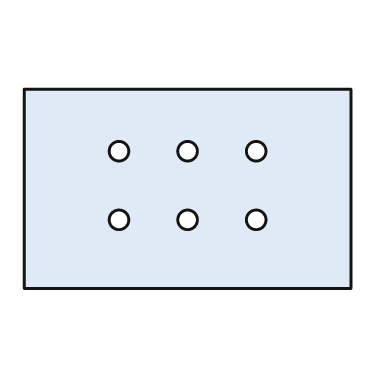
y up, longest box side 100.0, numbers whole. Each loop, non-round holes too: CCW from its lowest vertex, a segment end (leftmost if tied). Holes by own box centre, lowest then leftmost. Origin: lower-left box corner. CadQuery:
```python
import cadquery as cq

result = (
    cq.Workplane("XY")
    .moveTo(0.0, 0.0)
    .lineTo(100.0, 0.0)
    .lineTo(100.0, 61.0)
    .lineTo(0.0, 61.0)
    .close()
    .moveTo(29.0, 21.0)
    .circle(3.0)
    .moveTo(50.0, 21.0)
    .circle(3.0)
    .moveTo(71.0, 21.0)
    .circle(3.0)
    .moveTo(29.0, 42.0)
    .circle(3.0)
    .moveTo(50.0, 42.0)
    .circle(3.0)
    .moveTo(71.0, 42.0)
    .circle(3.0)
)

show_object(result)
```